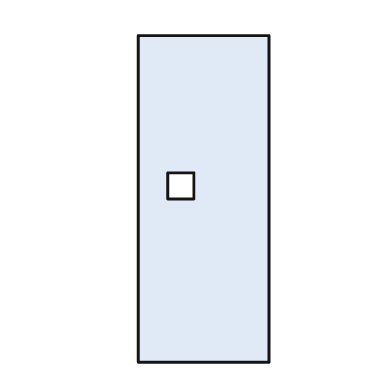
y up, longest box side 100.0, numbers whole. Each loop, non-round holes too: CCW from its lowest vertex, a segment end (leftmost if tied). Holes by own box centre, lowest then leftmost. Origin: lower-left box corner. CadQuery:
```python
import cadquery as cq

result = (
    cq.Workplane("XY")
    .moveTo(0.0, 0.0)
    .lineTo(40.0, 0.0)
    .lineTo(40.0, 100.0)
    .lineTo(0.0, 100.0)
    .close()
    .moveTo(9.0, 50.0)
    .lineTo(17.0, 50.0)
    .lineTo(17.0, 58.0)
    .lineTo(9.0, 58.0)
    .close()
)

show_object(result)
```